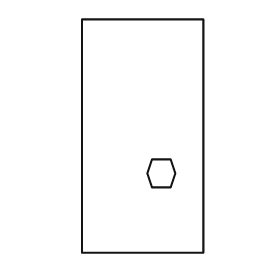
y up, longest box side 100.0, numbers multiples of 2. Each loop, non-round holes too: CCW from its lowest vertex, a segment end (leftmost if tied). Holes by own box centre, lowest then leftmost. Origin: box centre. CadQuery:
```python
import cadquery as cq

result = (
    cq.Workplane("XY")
    .moveTo(-26.0, -50.0)
    .lineTo(26.0, -50.0)
    .lineTo(26.0, 50.0)
    .lineTo(-26.0, 50.0)
    .close()
    .moveTo(4.0, -22.0)
    .lineTo(12.0, -22.0)
    .lineTo(14.0, -16.0)
    .lineTo(12.0, -10.0)
    .lineTo(4.0, -10.0)
    .lineTo(2.0, -16.0)
    .close()
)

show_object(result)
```